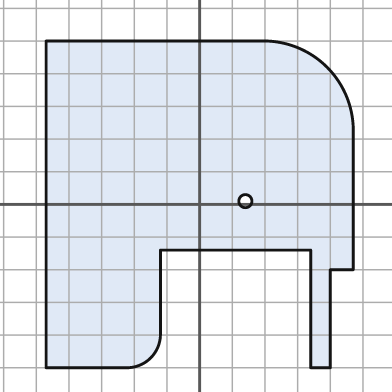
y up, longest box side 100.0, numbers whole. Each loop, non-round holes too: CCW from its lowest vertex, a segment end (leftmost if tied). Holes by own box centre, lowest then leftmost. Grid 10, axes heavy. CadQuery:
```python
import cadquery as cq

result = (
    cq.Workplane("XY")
    .moveTo(-47.0, -50.0)
    .lineTo(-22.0, -50.0)
    .threePointArc((-15.0, -47.0), (-12.0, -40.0))
    .lineTo(-12.0, -14.0)
    .lineTo(34.0, -14.0)
    .lineTo(34.0, -50.0)
    .lineTo(40.0, -50.0)
    .lineTo(40.0, -20.0)
    .lineTo(47.0, -20.0)
    .lineTo(47.0, 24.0)
    .threePointArc((39.0, 42.0), (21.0, 50.0))
    .lineTo(-47.0, 50.0)
    .close()
    .moveTo(14.0, 1.0)
    .circle(2.0)
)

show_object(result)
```